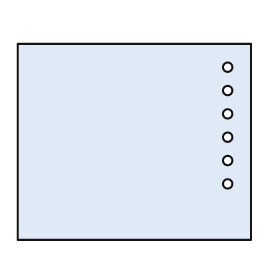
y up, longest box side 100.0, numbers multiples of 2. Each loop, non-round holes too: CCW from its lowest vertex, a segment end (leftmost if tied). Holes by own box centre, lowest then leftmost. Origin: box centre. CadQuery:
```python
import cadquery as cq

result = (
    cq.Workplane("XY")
    .moveTo(-50.0, -42.0)
    .lineTo(50.0, -42.0)
    .lineTo(50.0, 42.0)
    .lineTo(-50.0, 42.0)
    .close()
    .moveTo(40.0, -18.0)
    .circle(2.0)
    .moveTo(40.0, -8.0)
    .circle(2.0)
    .moveTo(40.0, 2.0)
    .circle(2.0)
    .moveTo(40.0, 12.0)
    .circle(2.0)
    .moveTo(40.0, 22.0)
    .circle(2.0)
    .moveTo(40.0, 32.0)
    .circle(2.0)
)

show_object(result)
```